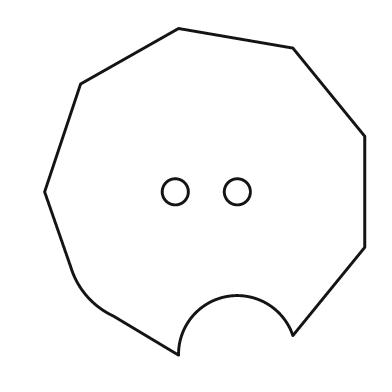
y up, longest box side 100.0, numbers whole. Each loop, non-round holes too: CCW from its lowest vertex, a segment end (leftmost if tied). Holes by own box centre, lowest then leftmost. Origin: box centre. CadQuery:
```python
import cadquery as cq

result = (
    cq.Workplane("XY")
    .moveTo(-8.0, -50.0)
    .threePointArc((7.0, -32.0), (27.0, -44.0))
    .lineTo(49.0, -17.0)
    .lineTo(49.0, 17.0)
    .lineTo(27.0, 44.0)
    .lineTo(-8.0, 50.0)
    .lineTo(-38.0, 33.0)
    .lineTo(-49.0, 0.0)
    .lineTo(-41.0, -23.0)
    .threePointArc((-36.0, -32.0), (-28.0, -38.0))
    .close()
    .moveTo(-9.0, 0.0)
    .circle(4.0)
    .moveTo(10.0, 0.0)
    .circle(4.0)
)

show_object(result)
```